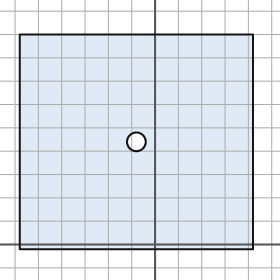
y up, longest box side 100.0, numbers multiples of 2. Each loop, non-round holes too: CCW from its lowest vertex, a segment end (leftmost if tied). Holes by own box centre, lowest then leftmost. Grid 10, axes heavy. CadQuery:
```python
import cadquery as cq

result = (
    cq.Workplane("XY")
    .moveTo(-58.0, -2.0)
    .lineTo(42.0, -2.0)
    .lineTo(42.0, 90.0)
    .lineTo(-58.0, 90.0)
    .close()
    .moveTo(-8.0, 44.0)
    .circle(4.0)
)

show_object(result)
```